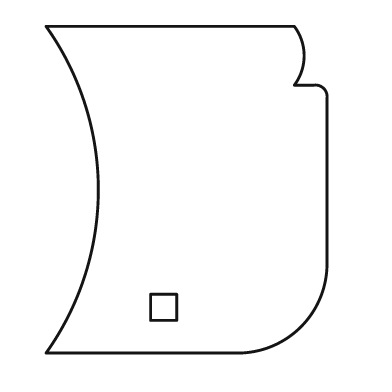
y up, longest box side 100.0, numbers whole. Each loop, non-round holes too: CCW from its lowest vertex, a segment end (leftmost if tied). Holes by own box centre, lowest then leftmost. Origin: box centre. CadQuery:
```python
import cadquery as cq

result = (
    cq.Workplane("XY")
    .moveTo(-43.0, -50.0)
    .lineTo(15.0, -50.0)
    .threePointArc((35.0, -42.0), (43.0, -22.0))
    .lineTo(43.0, 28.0)
    .threePointArc((42.0, 31.0), (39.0, 32.0))
    .lineTo(33.0, 32.0)
    .threePointArc((36.0, 41.0), (33.0, 50.0))
    .lineTo(-43.0, 50.0)
    .threePointArc((-27.0, 0.0), (-43.0, -50.0))
    .close()
    .moveTo(-11.0, -40.0)
    .lineTo(-3.0, -40.0)
    .lineTo(-3.0, -32.0)
    .lineTo(-11.0, -32.0)
    .close()
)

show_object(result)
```